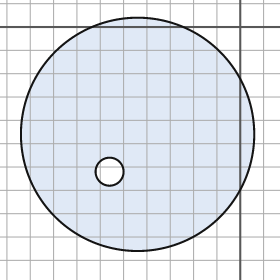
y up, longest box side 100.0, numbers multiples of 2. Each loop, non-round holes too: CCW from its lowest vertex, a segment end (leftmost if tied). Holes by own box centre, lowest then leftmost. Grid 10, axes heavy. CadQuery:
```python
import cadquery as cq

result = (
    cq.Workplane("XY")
    .moveTo(-44.0, -46.0)
    .circle(50.0)
    .moveTo(-56.0, -62.0)
    .circle(6.0)
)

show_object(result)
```